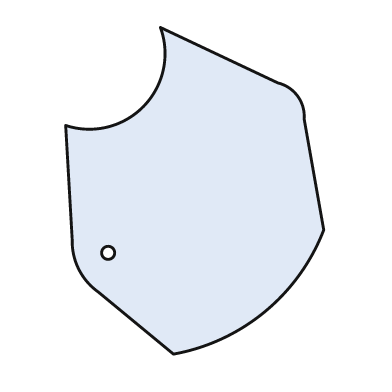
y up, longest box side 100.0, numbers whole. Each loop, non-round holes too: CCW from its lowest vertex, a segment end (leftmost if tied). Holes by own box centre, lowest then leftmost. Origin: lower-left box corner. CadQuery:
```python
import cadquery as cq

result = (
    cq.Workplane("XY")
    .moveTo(33.0, 0.0)
    .threePointArc((61.0, 13.0), (79.0, 38.0))
    .lineTo(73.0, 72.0)
    .threePointArc((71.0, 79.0), (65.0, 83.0))
    .lineTo(29.0, 100.0)
    .threePointArc((24.0, 76.0), (0.0, 70.0))
    .lineTo(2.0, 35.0)
    .threePointArc((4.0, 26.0), (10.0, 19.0))
    .close()
    .moveTo(13.0, 31.0)
    .circle(2.0)
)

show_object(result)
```